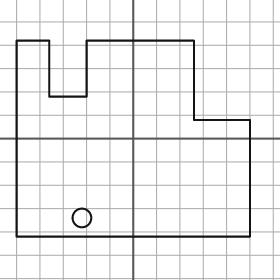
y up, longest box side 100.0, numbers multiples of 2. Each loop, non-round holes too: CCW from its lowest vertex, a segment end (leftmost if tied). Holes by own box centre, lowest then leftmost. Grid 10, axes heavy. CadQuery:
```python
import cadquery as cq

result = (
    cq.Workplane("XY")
    .moveTo(-50.0, -42.0)
    .lineTo(50.0, -42.0)
    .lineTo(50.0, 8.0)
    .lineTo(26.0, 8.0)
    .lineTo(26.0, 42.0)
    .lineTo(-20.0, 42.0)
    .lineTo(-20.0, 18.0)
    .lineTo(-36.0, 18.0)
    .lineTo(-36.0, 42.0)
    .lineTo(-50.0, 42.0)
    .close()
    .moveTo(-22.0, -34.0)
    .circle(4.0)
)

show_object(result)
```